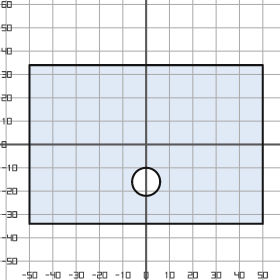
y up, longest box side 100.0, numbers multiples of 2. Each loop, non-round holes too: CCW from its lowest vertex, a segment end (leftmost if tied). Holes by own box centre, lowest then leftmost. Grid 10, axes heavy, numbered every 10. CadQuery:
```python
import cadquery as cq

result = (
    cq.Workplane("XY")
    .moveTo(-50.0, -34.0)
    .lineTo(50.0, -34.0)
    .lineTo(50.0, 34.0)
    .lineTo(-50.0, 34.0)
    .close()
    .moveTo(0.0, -16.0)
    .circle(6.0)
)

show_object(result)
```